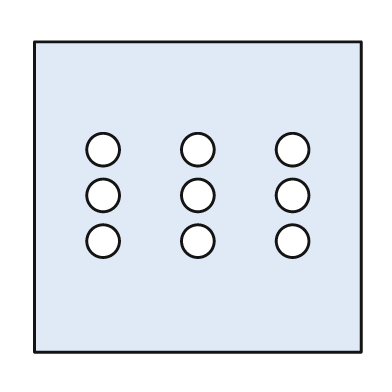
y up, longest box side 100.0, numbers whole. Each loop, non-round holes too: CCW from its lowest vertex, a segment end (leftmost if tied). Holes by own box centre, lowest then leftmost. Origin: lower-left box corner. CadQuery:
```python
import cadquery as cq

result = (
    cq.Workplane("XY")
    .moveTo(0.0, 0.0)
    .lineTo(100.0, 0.0)
    .lineTo(100.0, 95.0)
    .lineTo(0.0, 95.0)
    .close()
    .moveTo(21.0, 34.0)
    .circle(5.0)
    .moveTo(50.0, 34.0)
    .circle(5.0)
    .moveTo(79.0, 34.0)
    .circle(5.0)
    .moveTo(21.0, 48.0)
    .circle(5.0)
    .moveTo(50.0, 48.0)
    .circle(5.0)
    .moveTo(79.0, 48.0)
    .circle(5.0)
    .moveTo(21.0, 62.0)
    .circle(5.0)
    .moveTo(50.0, 62.0)
    .circle(5.0)
    .moveTo(79.0, 62.0)
    .circle(5.0)
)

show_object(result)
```